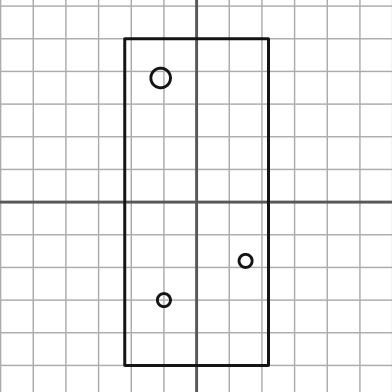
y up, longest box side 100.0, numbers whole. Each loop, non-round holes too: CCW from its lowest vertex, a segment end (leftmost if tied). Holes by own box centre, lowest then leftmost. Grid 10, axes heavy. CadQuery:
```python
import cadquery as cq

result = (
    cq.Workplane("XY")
    .moveTo(-22.0, -50.0)
    .lineTo(22.0, -50.0)
    .lineTo(22.0, 50.0)
    .lineTo(-22.0, 50.0)
    .close()
    .moveTo(-10.0, -30.0)
    .circle(2.0)
    .moveTo(15.0, -18.0)
    .circle(2.0)
    .moveTo(-11.0, 38.0)
    .circle(3.0)
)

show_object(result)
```